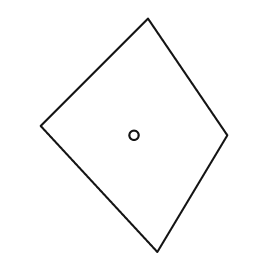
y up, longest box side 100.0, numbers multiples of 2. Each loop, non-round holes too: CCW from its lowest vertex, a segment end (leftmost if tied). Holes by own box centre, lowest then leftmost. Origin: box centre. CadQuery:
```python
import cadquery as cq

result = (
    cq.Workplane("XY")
    .moveTo(10.0, -50.0)
    .lineTo(40.0, 0.0)
    .lineTo(6.0, 50.0)
    .lineTo(-40.0, 4.0)
    .close()
    .moveTo(0.0, 0.0)
    .circle(2.0)
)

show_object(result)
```